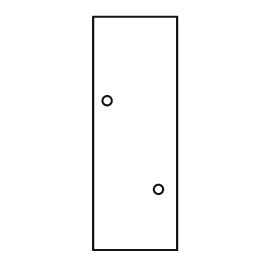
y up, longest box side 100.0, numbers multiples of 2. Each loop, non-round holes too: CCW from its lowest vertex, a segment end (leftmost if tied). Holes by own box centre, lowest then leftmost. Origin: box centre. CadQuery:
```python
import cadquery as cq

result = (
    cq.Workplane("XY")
    .moveTo(-18.0, -50.0)
    .lineTo(18.0, -50.0)
    .lineTo(18.0, 50.0)
    .lineTo(-18.0, 50.0)
    .close()
    .moveTo(10.0, -24.0)
    .circle(2.0)
    .moveTo(-12.0, 14.0)
    .circle(2.0)
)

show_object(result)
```